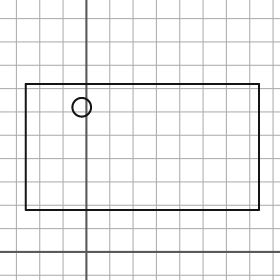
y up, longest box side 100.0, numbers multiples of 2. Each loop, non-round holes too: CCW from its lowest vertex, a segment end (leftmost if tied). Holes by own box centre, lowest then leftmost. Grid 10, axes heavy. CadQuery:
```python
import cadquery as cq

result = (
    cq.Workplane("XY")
    .moveTo(-26.0, 18.0)
    .lineTo(74.0, 18.0)
    .lineTo(74.0, 72.0)
    .lineTo(-26.0, 72.0)
    .close()
    .moveTo(-2.0, 62.0)
    .circle(4.0)
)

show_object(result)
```